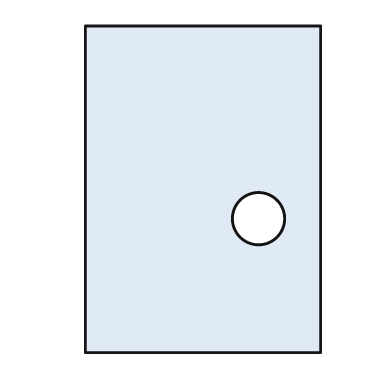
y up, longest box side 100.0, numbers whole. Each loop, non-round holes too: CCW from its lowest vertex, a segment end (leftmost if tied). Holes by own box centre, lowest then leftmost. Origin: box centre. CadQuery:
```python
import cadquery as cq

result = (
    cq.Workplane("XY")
    .moveTo(-36.0, -50.0)
    .lineTo(36.0, -50.0)
    .lineTo(36.0, 50.0)
    .lineTo(-36.0, 50.0)
    .close()
    .moveTo(17.0, -9.0)
    .circle(8.0)
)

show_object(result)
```